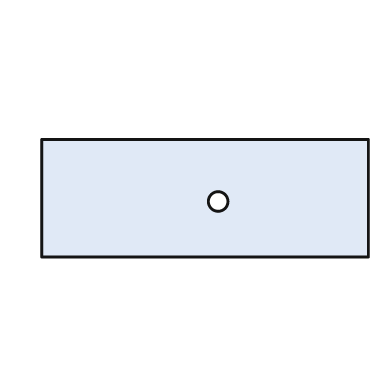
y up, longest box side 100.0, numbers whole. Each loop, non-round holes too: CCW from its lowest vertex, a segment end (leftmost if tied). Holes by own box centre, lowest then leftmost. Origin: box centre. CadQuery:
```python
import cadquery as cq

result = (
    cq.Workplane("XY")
    .moveTo(-50.0, -18.0)
    .lineTo(50.0, -18.0)
    .lineTo(50.0, 18.0)
    .lineTo(-50.0, 18.0)
    .close()
    .moveTo(4.0, -1.0)
    .circle(3.0)
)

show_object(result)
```